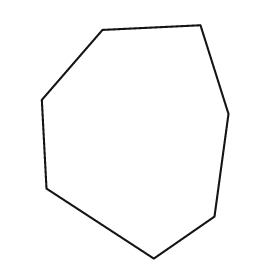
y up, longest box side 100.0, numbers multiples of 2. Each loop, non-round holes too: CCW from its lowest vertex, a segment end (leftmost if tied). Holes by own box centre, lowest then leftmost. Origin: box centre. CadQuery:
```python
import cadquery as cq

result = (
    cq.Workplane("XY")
    .moveTo(8.0, -50.0)
    .lineTo(34.0, -32.0)
    .lineTo(40.0, 12.0)
    .lineTo(28.0, 50.0)
    .lineTo(-14.0, 48.0)
    .lineTo(-40.0, 18.0)
    .lineTo(-38.0, -20.0)
    .close()
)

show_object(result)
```